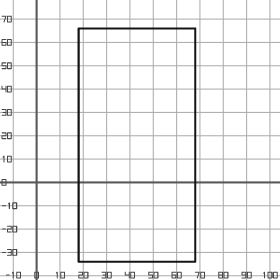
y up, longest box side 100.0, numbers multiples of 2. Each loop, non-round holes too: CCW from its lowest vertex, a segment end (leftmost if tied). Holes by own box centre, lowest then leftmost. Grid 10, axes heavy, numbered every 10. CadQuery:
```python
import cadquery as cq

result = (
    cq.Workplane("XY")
    .moveTo(18.0, -34.0)
    .lineTo(68.0, -34.0)
    .lineTo(68.0, 66.0)
    .lineTo(18.0, 66.0)
    .close()
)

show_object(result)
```